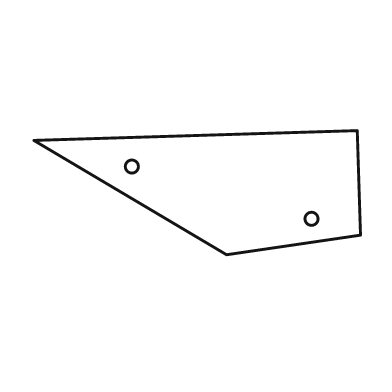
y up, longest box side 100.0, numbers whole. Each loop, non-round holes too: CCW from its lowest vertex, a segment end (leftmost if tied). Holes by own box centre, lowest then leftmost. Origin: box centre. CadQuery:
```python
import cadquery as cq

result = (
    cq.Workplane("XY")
    .moveTo(9.0, -19.0)
    .lineTo(50.0, -13.0)
    .lineTo(49.0, 19.0)
    .lineTo(-50.0, 16.0)
    .close()
    .moveTo(35.0, -8.0)
    .circle(2.0)
    .moveTo(-20.0, 8.0)
    .circle(2.0)
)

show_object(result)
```